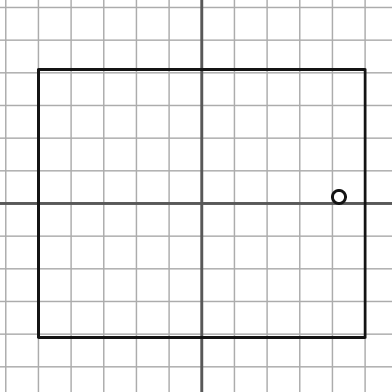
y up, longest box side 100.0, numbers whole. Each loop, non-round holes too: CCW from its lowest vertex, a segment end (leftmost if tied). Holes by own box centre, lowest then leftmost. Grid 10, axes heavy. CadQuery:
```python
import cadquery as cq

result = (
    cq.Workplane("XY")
    .moveTo(-50.0, -41.0)
    .lineTo(50.0, -41.0)
    .lineTo(50.0, 41.0)
    .lineTo(-50.0, 41.0)
    .close()
    .moveTo(42.0, 2.0)
    .circle(2.0)
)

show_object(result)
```